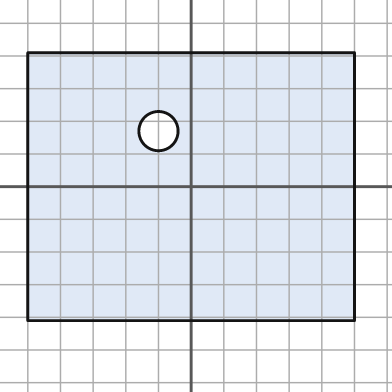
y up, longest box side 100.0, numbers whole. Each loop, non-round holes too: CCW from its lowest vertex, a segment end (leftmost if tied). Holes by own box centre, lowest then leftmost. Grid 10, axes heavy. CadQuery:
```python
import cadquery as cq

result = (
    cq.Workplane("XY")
    .moveTo(-50.0, -41.0)
    .lineTo(50.0, -41.0)
    .lineTo(50.0, 41.0)
    .lineTo(-50.0, 41.0)
    .close()
    .moveTo(-10.0, 17.0)
    .circle(6.0)
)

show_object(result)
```